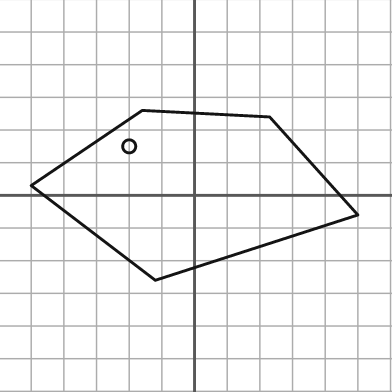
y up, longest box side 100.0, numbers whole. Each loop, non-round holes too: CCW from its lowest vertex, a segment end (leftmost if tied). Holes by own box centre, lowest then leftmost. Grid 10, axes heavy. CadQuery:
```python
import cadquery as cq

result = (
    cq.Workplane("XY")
    .moveTo(-12.0, -26.0)
    .lineTo(50.0, -6.0)
    .lineTo(23.0, 24.0)
    .lineTo(-16.0, 26.0)
    .lineTo(-50.0, 3.0)
    .close()
    .moveTo(-20.0, 15.0)
    .circle(2.0)
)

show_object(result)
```